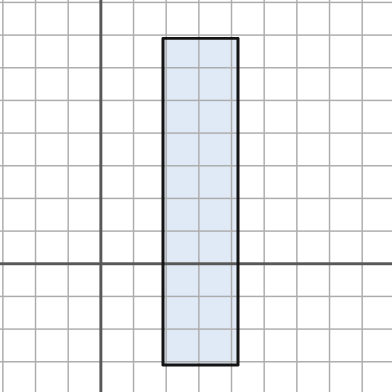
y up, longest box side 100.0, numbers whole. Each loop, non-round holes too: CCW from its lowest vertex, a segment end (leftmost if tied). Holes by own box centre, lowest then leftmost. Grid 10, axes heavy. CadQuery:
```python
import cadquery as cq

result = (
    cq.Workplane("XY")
    .moveTo(19.0, -31.0)
    .lineTo(42.0, -31.0)
    .lineTo(42.0, 69.0)
    .lineTo(19.0, 69.0)
    .close()
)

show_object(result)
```